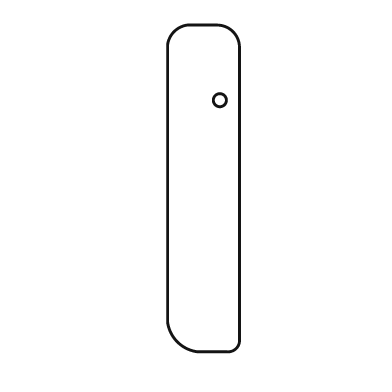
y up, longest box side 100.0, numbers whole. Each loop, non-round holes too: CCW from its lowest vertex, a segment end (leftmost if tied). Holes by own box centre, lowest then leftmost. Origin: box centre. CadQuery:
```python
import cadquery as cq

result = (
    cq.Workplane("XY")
    .moveTo(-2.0, -50.0)
    .lineTo(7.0, -50.0)
    .threePointArc((10.0, -49.0), (11.0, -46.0))
    .lineTo(11.0, 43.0)
    .threePointArc((9.0, 48.0), (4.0, 50.0))
    .lineTo(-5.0, 50.0)
    .threePointArc((-9.0, 48.0), (-11.0, 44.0))
    .lineTo(-11.0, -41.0)
    .threePointArc((-8.0, -47.0), (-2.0, -50.0))
    .close()
    .moveTo(5.0, 27.0)
    .circle(2.0)
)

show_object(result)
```